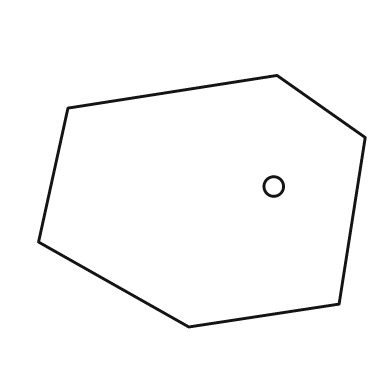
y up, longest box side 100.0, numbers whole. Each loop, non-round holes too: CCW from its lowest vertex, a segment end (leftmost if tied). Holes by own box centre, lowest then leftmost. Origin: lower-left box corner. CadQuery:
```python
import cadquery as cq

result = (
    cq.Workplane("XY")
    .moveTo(46.0, 0.0)
    .lineTo(92.0, 7.0)
    .lineTo(100.0, 58.0)
    .lineTo(73.0, 77.0)
    .lineTo(9.0, 67.0)
    .lineTo(0.0, 26.0)
    .close()
    .moveTo(72.0, 43.0)
    .circle(3.0)
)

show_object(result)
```